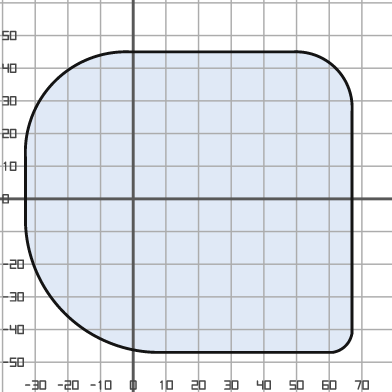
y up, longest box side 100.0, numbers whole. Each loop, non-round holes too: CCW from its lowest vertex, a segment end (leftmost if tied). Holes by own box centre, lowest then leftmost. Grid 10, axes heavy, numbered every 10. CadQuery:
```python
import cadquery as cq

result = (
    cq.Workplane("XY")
    .moveTo(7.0, -47.0)
    .lineTo(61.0, -47.0)
    .threePointArc((65.0, -45.0), (67.0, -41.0))
    .lineTo(67.0, 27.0)
    .threePointArc((62.0, 40.0), (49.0, 45.0))
    .lineTo(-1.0, 45.0)
    .threePointArc((-24.0, 36.0), (-33.0, 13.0))
    .lineTo(-33.0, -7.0)
    .threePointArc((-21.0, -35.0), (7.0, -47.0))
    .close()
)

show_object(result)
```